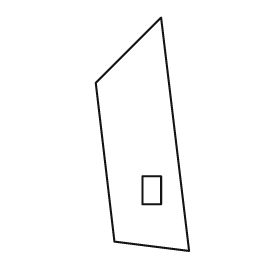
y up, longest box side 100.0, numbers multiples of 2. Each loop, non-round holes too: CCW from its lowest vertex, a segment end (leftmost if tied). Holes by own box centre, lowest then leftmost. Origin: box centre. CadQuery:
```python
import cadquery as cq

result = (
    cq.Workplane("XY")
    .moveTo(20.0, -50.0)
    .lineTo(8.0, 50.0)
    .lineTo(-20.0, 22.0)
    .lineTo(-12.0, -46.0)
    .close()
    .moveTo(0.0, -30.0)
    .lineTo(8.0, -30.0)
    .lineTo(8.0, -18.0)
    .lineTo(0.0, -18.0)
    .close()
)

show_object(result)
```